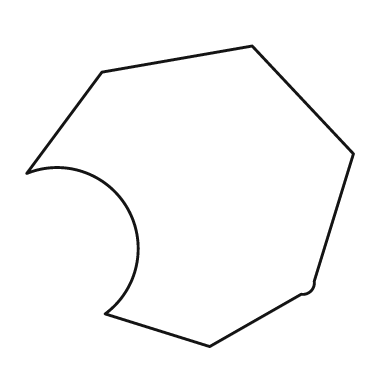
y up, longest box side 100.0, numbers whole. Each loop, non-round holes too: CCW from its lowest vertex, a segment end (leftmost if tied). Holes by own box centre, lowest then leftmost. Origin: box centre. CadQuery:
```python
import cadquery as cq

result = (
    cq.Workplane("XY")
    .moveTo(6.0, -46.0)
    .lineTo(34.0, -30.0)
    .threePointArc((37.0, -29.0), (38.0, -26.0))
    .lineTo(50.0, 13.0)
    .lineTo(19.0, 46.0)
    .lineTo(-27.0, 38.0)
    .lineTo(-50.0, 7.0)
    .threePointArc((-19.0, -4.0), (-26.0, -36.0))
    .close()
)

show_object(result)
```